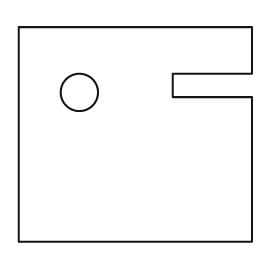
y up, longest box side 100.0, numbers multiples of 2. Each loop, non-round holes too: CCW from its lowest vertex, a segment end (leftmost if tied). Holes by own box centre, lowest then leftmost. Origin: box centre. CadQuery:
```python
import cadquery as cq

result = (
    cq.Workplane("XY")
    .moveTo(-50.0, -46.0)
    .lineTo(50.0, -46.0)
    .lineTo(50.0, 16.0)
    .lineTo(16.0, 16.0)
    .lineTo(16.0, 26.0)
    .lineTo(50.0, 26.0)
    .lineTo(50.0, 46.0)
    .lineTo(-50.0, 46.0)
    .close()
    .moveTo(-24.0, 18.0)
    .circle(8.0)
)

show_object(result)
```